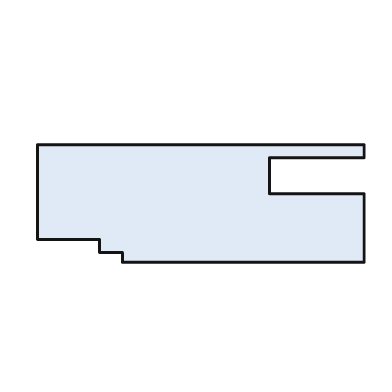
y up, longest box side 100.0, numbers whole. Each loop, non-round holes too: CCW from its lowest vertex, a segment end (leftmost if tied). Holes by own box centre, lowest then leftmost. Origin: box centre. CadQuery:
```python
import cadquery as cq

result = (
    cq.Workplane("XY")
    .moveTo(-24.0, -18.0)
    .lineTo(50.0, -18.0)
    .lineTo(50.0, 3.0)
    .lineTo(21.0, 3.0)
    .lineTo(21.0, 14.0)
    .lineTo(50.0, 14.0)
    .lineTo(50.0, 18.0)
    .lineTo(-50.0, 18.0)
    .lineTo(-50.0, -11.0)
    .lineTo(-31.0, -11.0)
    .lineTo(-31.0, -15.0)
    .lineTo(-24.0, -15.0)
    .close()
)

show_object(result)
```